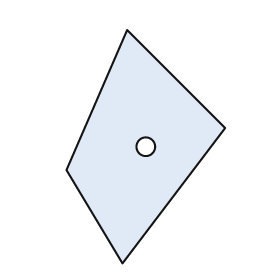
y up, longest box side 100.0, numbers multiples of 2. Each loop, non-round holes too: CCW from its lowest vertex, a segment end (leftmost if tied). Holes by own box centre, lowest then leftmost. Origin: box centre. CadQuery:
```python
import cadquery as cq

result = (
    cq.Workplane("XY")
    .moveTo(-10.0, -50.0)
    .lineTo(34.0, 8.0)
    .lineTo(-8.0, 50.0)
    .lineTo(-34.0, -10.0)
    .close()
    .moveTo(0.0, 0.0)
    .circle(4.0)
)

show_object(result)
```